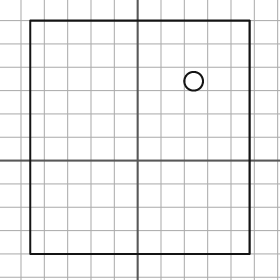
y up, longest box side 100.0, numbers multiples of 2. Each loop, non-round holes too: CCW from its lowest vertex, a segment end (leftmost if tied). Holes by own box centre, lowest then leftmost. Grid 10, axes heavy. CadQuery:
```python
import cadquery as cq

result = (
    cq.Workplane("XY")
    .moveTo(-46.0, -40.0)
    .lineTo(48.0, -40.0)
    .lineTo(48.0, 60.0)
    .lineTo(-46.0, 60.0)
    .close()
    .moveTo(24.0, 34.0)
    .circle(4.0)
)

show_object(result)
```